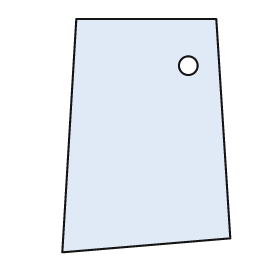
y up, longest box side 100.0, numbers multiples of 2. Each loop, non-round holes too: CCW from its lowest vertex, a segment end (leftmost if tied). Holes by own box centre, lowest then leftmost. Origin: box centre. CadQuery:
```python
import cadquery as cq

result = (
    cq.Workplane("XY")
    .moveTo(-36.0, -50.0)
    .lineTo(36.0, -44.0)
    .lineTo(30.0, 50.0)
    .lineTo(-30.0, 50.0)
    .close()
    .moveTo(18.0, 30.0)
    .circle(4.0)
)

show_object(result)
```